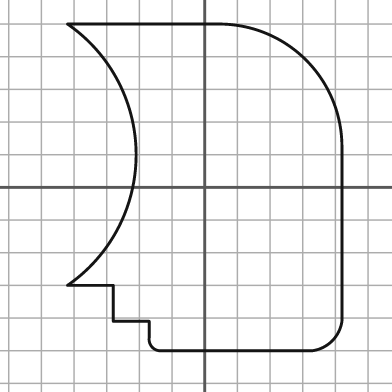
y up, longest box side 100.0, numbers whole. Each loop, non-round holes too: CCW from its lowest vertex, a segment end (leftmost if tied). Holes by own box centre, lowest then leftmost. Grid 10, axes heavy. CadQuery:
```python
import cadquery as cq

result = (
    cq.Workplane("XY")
    .moveTo(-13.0, -50.0)
    .lineTo(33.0, -50.0)
    .threePointArc((39.0, -47.0), (42.0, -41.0))
    .lineTo(42.0, 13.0)
    .threePointArc((31.0, 39.0), (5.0, 50.0))
    .lineTo(-42.0, 50.0)
    .threePointArc((-21.0, 10.0), (-42.0, -30.0))
    .lineTo(-28.0, -30.0)
    .lineTo(-28.0, -41.0)
    .lineTo(-17.0, -41.0)
    .lineTo(-17.0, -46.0)
    .threePointArc((-16.0, -49.0), (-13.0, -50.0))
    .close()
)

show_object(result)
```